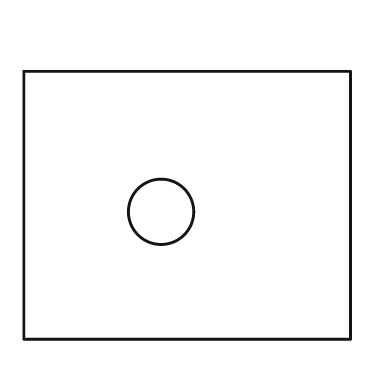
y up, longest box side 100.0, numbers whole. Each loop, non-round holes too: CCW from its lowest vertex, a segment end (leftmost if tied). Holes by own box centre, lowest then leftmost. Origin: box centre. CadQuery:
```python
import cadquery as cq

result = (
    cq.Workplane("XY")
    .moveTo(-50.0, -41.0)
    .lineTo(50.0, -41.0)
    .lineTo(50.0, 41.0)
    .lineTo(-50.0, 41.0)
    .close()
    .moveTo(-8.0, -2.0)
    .circle(10.0)
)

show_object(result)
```